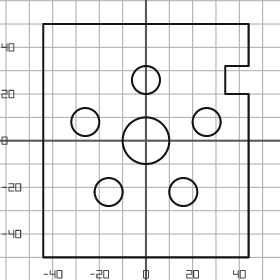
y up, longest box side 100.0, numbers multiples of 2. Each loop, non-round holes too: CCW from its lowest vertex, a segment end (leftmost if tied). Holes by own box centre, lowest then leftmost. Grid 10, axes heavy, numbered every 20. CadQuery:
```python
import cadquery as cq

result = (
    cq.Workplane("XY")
    .moveTo(-44.0, -50.0)
    .lineTo(44.0, -50.0)
    .lineTo(44.0, 20.0)
    .lineTo(34.0, 20.0)
    .lineTo(34.0, 32.0)
    .lineTo(44.0, 32.0)
    .lineTo(44.0, 50.0)
    .lineTo(-44.0, 50.0)
    .close()
    .moveTo(-16.0, -22.0)
    .circle(6.0)
    .moveTo(16.0, -22.0)
    .circle(6.0)
    .moveTo(0.0, 0.0)
    .circle(10.0)
    .moveTo(-26.0, 8.0)
    .circle(6.0)
    .moveTo(26.0, 8.0)
    .circle(6.0)
    .moveTo(0.0, 26.0)
    .circle(6.0)
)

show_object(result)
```